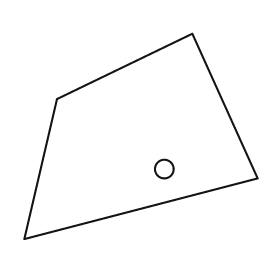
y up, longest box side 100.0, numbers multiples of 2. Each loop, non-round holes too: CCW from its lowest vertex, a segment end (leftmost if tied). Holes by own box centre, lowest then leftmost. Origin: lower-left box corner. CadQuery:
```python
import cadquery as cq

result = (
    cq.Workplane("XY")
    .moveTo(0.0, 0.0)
    .lineTo(100.0, 26.0)
    .lineTo(72.0, 88.0)
    .lineTo(14.0, 60.0)
    .close()
    .moveTo(60.0, 30.0)
    .circle(4.0)
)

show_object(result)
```